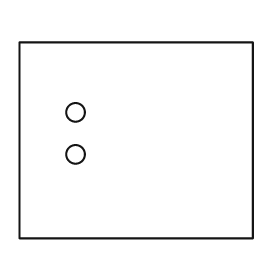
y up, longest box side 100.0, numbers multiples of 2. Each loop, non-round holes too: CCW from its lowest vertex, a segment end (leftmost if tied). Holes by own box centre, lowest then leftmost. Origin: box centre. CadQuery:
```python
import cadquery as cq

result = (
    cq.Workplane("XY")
    .moveTo(-50.0, -42.0)
    .lineTo(50.0, -42.0)
    .lineTo(50.0, 42.0)
    .lineTo(-50.0, 42.0)
    .close()
    .moveTo(-26.0, -6.0)
    .circle(4.0)
    .moveTo(-26.0, 12.0)
    .circle(4.0)
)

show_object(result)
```